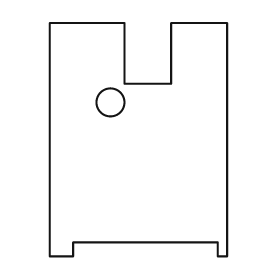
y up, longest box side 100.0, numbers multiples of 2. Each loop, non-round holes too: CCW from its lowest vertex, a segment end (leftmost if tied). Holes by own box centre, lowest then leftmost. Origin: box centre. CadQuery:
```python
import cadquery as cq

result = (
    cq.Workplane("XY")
    .moveTo(-38.0, -50.0)
    .lineTo(-28.0, -50.0)
    .lineTo(-28.0, -44.0)
    .lineTo(34.0, -44.0)
    .lineTo(34.0, -50.0)
    .lineTo(38.0, -50.0)
    .lineTo(38.0, 50.0)
    .lineTo(14.0, 50.0)
    .lineTo(14.0, 24.0)
    .lineTo(-6.0, 24.0)
    .lineTo(-6.0, 50.0)
    .lineTo(-38.0, 50.0)
    .close()
    .moveTo(-12.0, 16.0)
    .circle(6.0)
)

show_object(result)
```